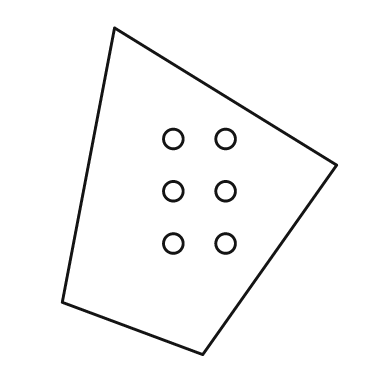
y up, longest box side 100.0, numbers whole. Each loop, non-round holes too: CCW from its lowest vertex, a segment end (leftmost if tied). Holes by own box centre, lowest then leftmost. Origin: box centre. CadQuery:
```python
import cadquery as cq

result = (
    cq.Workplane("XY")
    .moveTo(1.0, -50.0)
    .lineTo(42.0, 8.0)
    .lineTo(-26.0, 50.0)
    .lineTo(-42.0, -34.0)
    .close()
    .moveTo(-8.0, -16.0)
    .circle(3.0)
    .moveTo(8.0, -16.0)
    .circle(3.0)
    .moveTo(-8.0, 0.0)
    .circle(3.0)
    .moveTo(8.0, 0.0)
    .circle(3.0)
    .moveTo(-8.0, 16.0)
    .circle(3.0)
    .moveTo(8.0, 16.0)
    .circle(3.0)
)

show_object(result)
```